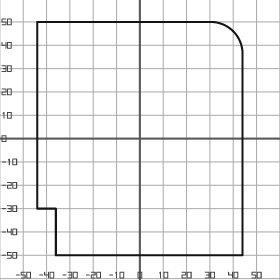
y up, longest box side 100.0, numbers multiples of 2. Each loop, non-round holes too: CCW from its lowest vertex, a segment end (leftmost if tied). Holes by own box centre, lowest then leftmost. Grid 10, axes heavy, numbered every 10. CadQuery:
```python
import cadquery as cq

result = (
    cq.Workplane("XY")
    .moveTo(-36.0, -50.0)
    .lineTo(44.0, -50.0)
    .lineTo(44.0, 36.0)
    .threePointArc((40.0, 46.0), (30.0, 50.0))
    .lineTo(-44.0, 50.0)
    .lineTo(-44.0, -30.0)
    .lineTo(-36.0, -30.0)
    .close()
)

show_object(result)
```